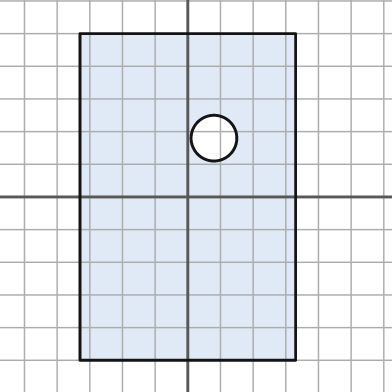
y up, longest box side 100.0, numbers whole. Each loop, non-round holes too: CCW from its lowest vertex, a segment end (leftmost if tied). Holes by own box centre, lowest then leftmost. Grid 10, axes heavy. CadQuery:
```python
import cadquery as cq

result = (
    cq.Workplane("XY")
    .moveTo(-33.0, -50.0)
    .lineTo(33.0, -50.0)
    .lineTo(33.0, 50.0)
    .lineTo(-33.0, 50.0)
    .close()
    .moveTo(8.0, 18.0)
    .circle(7.0)
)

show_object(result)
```